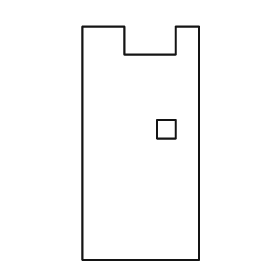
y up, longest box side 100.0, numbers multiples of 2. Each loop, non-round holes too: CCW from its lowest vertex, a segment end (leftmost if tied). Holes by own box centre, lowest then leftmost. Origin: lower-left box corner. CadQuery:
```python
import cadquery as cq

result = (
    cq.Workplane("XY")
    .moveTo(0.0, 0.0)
    .lineTo(50.0, 0.0)
    .lineTo(50.0, 100.0)
    .lineTo(40.0, 100.0)
    .lineTo(40.0, 88.0)
    .lineTo(18.0, 88.0)
    .lineTo(18.0, 100.0)
    .lineTo(0.0, 100.0)
    .close()
    .moveTo(32.0, 52.0)
    .lineTo(40.0, 52.0)
    .lineTo(40.0, 60.0)
    .lineTo(32.0, 60.0)
    .close()
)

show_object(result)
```